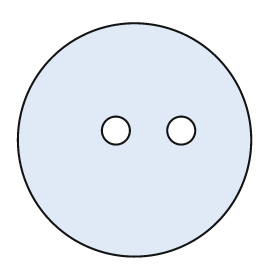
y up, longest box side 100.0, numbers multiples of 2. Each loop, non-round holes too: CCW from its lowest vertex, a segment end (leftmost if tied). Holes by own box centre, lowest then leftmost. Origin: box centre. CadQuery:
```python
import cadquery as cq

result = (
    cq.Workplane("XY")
    .moveTo(0.0, 0.0)
    .circle(50.0)
    .moveTo(-8.0, 4.0)
    .circle(6.0)
    .moveTo(20.0, 4.0)
    .circle(6.0)
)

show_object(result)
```